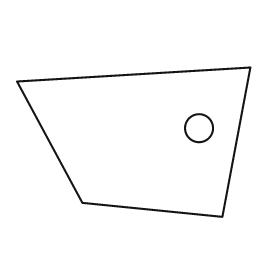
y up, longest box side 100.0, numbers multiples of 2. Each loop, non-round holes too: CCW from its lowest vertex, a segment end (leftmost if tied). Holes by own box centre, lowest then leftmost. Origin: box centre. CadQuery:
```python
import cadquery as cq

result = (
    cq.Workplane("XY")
    .moveTo(38.0, -32.0)
    .lineTo(50.0, 32.0)
    .lineTo(-50.0, 26.0)
    .lineTo(-22.0, -26.0)
    .close()
    .moveTo(28.0, 6.0)
    .circle(6.0)
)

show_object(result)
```